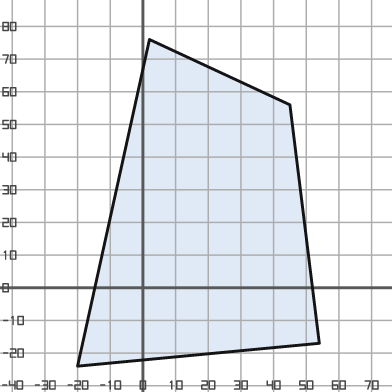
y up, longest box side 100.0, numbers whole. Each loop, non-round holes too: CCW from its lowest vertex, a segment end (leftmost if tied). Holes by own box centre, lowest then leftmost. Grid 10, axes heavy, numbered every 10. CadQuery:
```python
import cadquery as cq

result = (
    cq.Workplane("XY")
    .moveTo(-20.0, -24.0)
    .lineTo(54.0, -17.0)
    .lineTo(45.0, 56.0)
    .lineTo(2.0, 76.0)
    .close()
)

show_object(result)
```